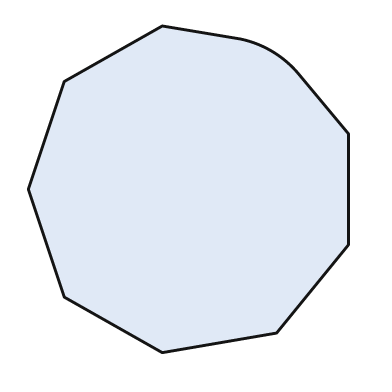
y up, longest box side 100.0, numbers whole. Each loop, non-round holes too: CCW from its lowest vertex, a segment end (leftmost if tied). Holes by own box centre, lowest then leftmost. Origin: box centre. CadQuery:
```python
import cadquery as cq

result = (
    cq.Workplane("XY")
    .moveTo(-8.0, -50.0)
    .lineTo(27.0, -44.0)
    .lineTo(49.0, -17.0)
    .lineTo(49.0, 17.0)
    .lineTo(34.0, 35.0)
    .threePointArc((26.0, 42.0), (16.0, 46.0))
    .lineTo(-8.0, 50.0)
    .lineTo(-38.0, 33.0)
    .lineTo(-49.0, 0.0)
    .lineTo(-38.0, -33.0)
    .close()
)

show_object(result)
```